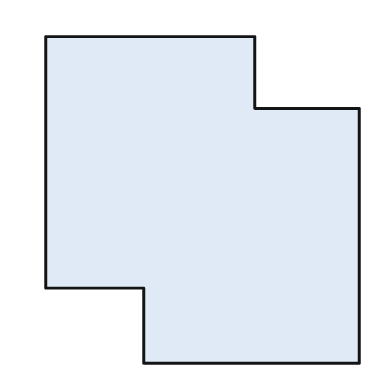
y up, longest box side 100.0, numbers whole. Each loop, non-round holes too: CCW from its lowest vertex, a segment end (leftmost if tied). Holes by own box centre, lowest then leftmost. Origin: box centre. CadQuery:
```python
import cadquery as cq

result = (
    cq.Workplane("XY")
    .moveTo(-18.0, -50.0)
    .lineTo(48.0, -50.0)
    .lineTo(48.0, 28.0)
    .lineTo(16.0, 28.0)
    .lineTo(16.0, 50.0)
    .lineTo(-48.0, 50.0)
    .lineTo(-48.0, -27.0)
    .lineTo(-18.0, -27.0)
    .close()
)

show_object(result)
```